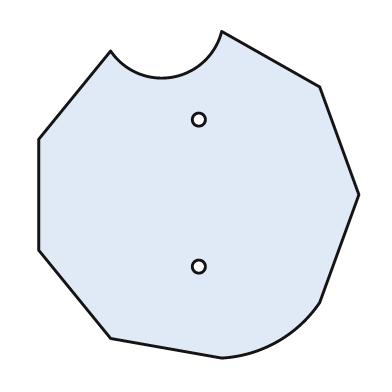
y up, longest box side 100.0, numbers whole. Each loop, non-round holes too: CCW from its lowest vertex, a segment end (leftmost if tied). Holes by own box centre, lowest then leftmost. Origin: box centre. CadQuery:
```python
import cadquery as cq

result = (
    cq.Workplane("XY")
    .moveTo(7.0, -50.0)
    .threePointArc((24.0, -45.0), (37.0, -33.0))
    .lineTo(49.0, 0.0)
    .lineTo(37.0, 33.0)
    .lineTo(7.0, 50.0)
    .threePointArc((-8.0, 36.0), (-27.0, 44.0))
    .lineTo(-49.0, 17.0)
    .lineTo(-49.0, -17.0)
    .lineTo(-27.0, -44.0)
    .close()
    .moveTo(0.0, -22.0)
    .circle(2.0)
    .moveTo(0.0, 23.0)
    .circle(2.0)
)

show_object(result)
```